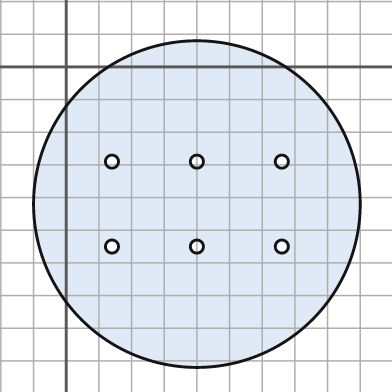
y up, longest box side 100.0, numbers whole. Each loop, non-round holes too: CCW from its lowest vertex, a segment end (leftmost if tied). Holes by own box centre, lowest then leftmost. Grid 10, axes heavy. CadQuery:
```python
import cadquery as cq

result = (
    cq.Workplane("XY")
    .moveTo(40.0, -42.0)
    .circle(50.0)
    .moveTo(14.0, -55.0)
    .circle(2.0)
    .moveTo(40.0, -55.0)
    .circle(2.0)
    .moveTo(66.0, -55.0)
    .circle(2.0)
    .moveTo(14.0, -29.0)
    .circle(2.0)
    .moveTo(40.0, -29.0)
    .circle(2.0)
    .moveTo(66.0, -29.0)
    .circle(2.0)
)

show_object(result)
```